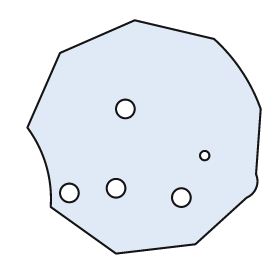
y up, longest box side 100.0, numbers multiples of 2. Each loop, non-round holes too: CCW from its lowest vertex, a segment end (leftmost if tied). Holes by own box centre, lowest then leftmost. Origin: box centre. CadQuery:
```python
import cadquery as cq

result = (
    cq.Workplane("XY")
    .moveTo(-12.0, -50.0)
    .lineTo(22.0, -46.0)
    .lineTo(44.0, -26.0)
    .threePointArc((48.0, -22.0), (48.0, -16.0))
    .lineTo(50.0, 12.0)
    .threePointArc((42.0, 28.0), (30.0, 42.0))
    .lineTo(-4.0, 50.0)
    .lineTo(-36.0, 36.0)
    .lineTo(-50.0, 4.0)
    .threePointArc((-42.0, -12.0), (-40.0, -30.0))
    .close()
    .moveTo(16.0, -26.0)
    .circle(4.0)
    .moveTo(-32.0, -24.0)
    .circle(4.0)
    .moveTo(-12.0, -22.0)
    .circle(4.0)
    .moveTo(26.0, -8.0)
    .circle(2.0)
    .moveTo(-8.0, 12.0)
    .circle(4.0)
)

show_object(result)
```